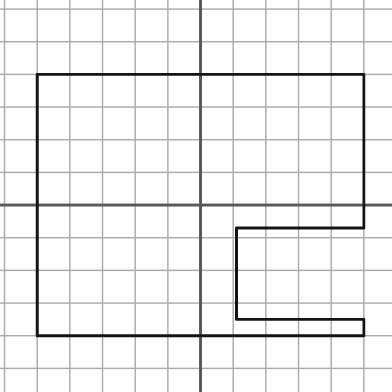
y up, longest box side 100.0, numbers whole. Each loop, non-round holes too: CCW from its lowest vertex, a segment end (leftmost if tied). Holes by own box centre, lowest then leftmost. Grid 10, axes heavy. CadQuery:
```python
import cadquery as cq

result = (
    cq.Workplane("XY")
    .moveTo(-50.0, -40.0)
    .lineTo(50.0, -40.0)
    .lineTo(50.0, -35.0)
    .lineTo(11.0, -35.0)
    .lineTo(11.0, -7.0)
    .lineTo(50.0, -7.0)
    .lineTo(50.0, 40.0)
    .lineTo(-50.0, 40.0)
    .close()
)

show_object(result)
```